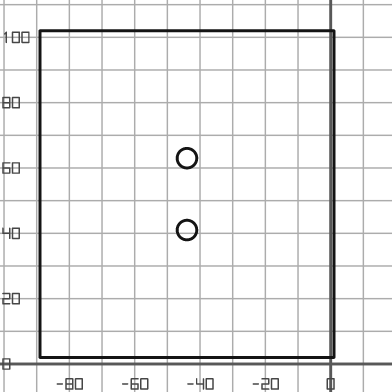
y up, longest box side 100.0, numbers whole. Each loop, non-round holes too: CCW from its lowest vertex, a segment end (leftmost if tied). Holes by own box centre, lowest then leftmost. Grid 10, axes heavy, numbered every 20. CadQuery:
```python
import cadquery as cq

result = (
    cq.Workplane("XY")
    .moveTo(-89.0, 2.0)
    .lineTo(1.0, 2.0)
    .lineTo(1.0, 102.0)
    .lineTo(-89.0, 102.0)
    .close()
    .moveTo(-44.0, 41.0)
    .circle(3.0)
    .moveTo(-44.0, 63.0)
    .circle(3.0)
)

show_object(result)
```